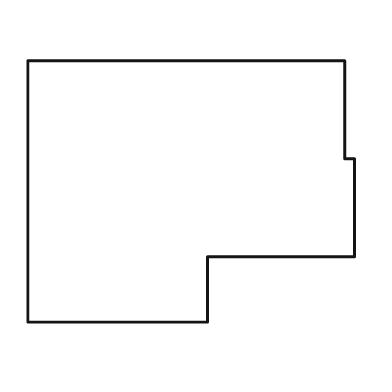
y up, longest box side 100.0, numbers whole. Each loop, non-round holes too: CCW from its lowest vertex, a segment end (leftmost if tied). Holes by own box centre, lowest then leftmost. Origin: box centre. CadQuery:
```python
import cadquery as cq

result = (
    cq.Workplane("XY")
    .moveTo(-50.0, -40.0)
    .lineTo(5.0, -40.0)
    .lineTo(5.0, -20.0)
    .lineTo(50.0, -20.0)
    .lineTo(50.0, 10.0)
    .lineTo(47.0, 10.0)
    .lineTo(47.0, 40.0)
    .lineTo(-50.0, 40.0)
    .close()
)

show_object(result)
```